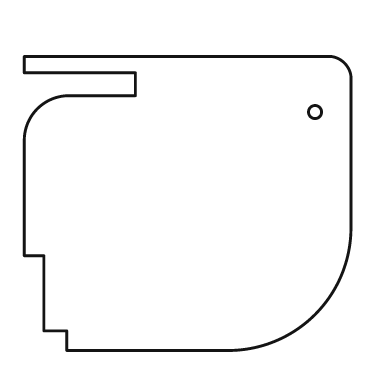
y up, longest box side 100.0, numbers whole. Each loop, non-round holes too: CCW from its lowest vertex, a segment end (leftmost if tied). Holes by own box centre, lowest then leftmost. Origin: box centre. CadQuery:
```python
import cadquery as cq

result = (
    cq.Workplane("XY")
    .moveTo(-37.0, -45.0)
    .lineTo(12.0, -45.0)
    .threePointArc((39.0, -34.0), (50.0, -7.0))
    .lineTo(50.0, 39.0)
    .threePointArc((48.0, 43.0), (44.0, 45.0))
    .lineTo(-50.0, 45.0)
    .lineTo(-50.0, 40.0)
    .lineTo(-16.0, 40.0)
    .lineTo(-16.0, 33.0)
    .lineTo(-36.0, 33.0)
    .threePointArc((-46.0, 29.0), (-50.0, 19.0))
    .lineTo(-50.0, -16.0)
    .lineTo(-44.0, -16.0)
    .lineTo(-44.0, -39.0)
    .lineTo(-37.0, -39.0)
    .close()
    .moveTo(39.0, 28.0)
    .circle(2.0)
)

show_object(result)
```